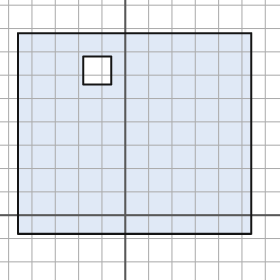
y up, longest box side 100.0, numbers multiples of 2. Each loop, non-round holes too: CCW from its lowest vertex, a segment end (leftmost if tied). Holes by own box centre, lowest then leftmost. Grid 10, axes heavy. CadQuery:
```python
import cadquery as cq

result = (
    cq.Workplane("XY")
    .moveTo(-46.0, -8.0)
    .lineTo(54.0, -8.0)
    .lineTo(54.0, 78.0)
    .lineTo(-46.0, 78.0)
    .close()
    .moveTo(-18.0, 56.0)
    .lineTo(-6.0, 56.0)
    .lineTo(-6.0, 68.0)
    .lineTo(-18.0, 68.0)
    .close()
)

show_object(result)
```